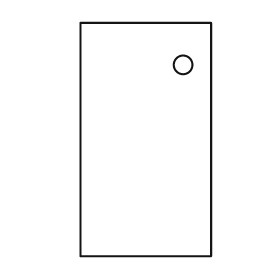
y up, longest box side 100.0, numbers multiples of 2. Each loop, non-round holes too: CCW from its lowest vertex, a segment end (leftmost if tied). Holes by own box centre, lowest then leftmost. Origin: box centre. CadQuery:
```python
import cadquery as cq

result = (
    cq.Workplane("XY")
    .moveTo(-28.0, -50.0)
    .lineTo(28.0, -50.0)
    .lineTo(28.0, 50.0)
    .lineTo(-28.0, 50.0)
    .close()
    .moveTo(16.0, 32.0)
    .circle(4.0)
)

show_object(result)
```